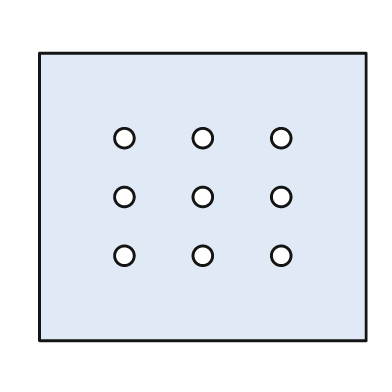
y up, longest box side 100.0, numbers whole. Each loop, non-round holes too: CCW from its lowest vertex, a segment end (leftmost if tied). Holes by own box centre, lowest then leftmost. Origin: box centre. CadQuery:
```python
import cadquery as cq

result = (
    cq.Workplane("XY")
    .moveTo(-50.0, -44.0)
    .lineTo(50.0, -44.0)
    .lineTo(50.0, 44.0)
    .lineTo(-50.0, 44.0)
    .close()
    .moveTo(-24.0, -18.0)
    .circle(3.0)
    .moveTo(0.0, -18.0)
    .circle(3.0)
    .moveTo(24.0, -18.0)
    .circle(3.0)
    .moveTo(-24.0, 0.0)
    .circle(3.0)
    .moveTo(0.0, 0.0)
    .circle(3.0)
    .moveTo(24.0, 0.0)
    .circle(3.0)
    .moveTo(-24.0, 18.0)
    .circle(3.0)
    .moveTo(0.0, 18.0)
    .circle(3.0)
    .moveTo(24.0, 18.0)
    .circle(3.0)
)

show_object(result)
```